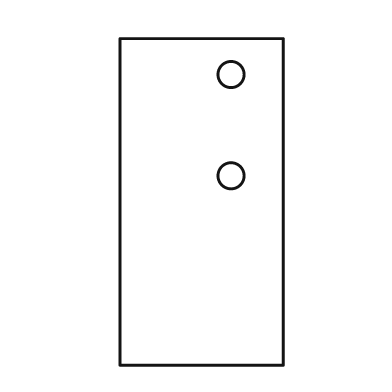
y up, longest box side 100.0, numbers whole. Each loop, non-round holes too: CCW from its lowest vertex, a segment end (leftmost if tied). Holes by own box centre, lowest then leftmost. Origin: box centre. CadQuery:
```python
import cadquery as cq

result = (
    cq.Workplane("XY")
    .moveTo(-25.0, -50.0)
    .lineTo(25.0, -50.0)
    .lineTo(25.0, 50.0)
    .lineTo(-25.0, 50.0)
    .close()
    .moveTo(9.0, 8.0)
    .circle(4.0)
    .moveTo(9.0, 39.0)
    .circle(4.0)
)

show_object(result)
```